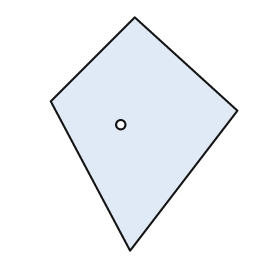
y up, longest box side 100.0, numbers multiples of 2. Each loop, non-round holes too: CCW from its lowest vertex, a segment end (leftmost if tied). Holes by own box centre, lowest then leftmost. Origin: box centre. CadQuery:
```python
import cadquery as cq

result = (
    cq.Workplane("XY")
    .moveTo(-6.0, -50.0)
    .lineTo(40.0, 10.0)
    .lineTo(-4.0, 50.0)
    .lineTo(-40.0, 14.0)
    .close()
    .moveTo(-10.0, 4.0)
    .circle(2.0)
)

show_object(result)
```